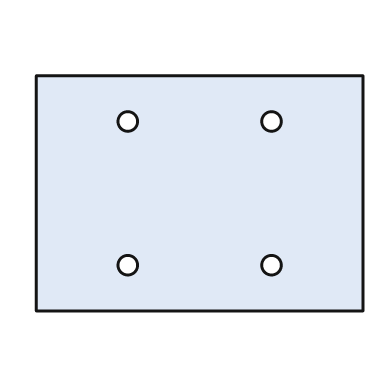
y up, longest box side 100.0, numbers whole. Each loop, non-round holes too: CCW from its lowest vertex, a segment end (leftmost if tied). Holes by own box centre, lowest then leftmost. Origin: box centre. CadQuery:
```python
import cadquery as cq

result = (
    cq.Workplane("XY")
    .moveTo(-50.0, -36.0)
    .lineTo(50.0, -36.0)
    .lineTo(50.0, 36.0)
    .lineTo(-50.0, 36.0)
    .close()
    .moveTo(-22.0, -22.0)
    .circle(3.0)
    .moveTo(22.0, -22.0)
    .circle(3.0)
    .moveTo(-22.0, 22.0)
    .circle(3.0)
    .moveTo(22.0, 22.0)
    .circle(3.0)
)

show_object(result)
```